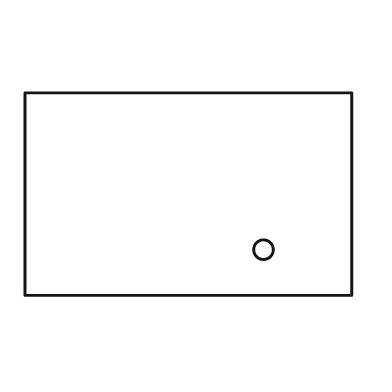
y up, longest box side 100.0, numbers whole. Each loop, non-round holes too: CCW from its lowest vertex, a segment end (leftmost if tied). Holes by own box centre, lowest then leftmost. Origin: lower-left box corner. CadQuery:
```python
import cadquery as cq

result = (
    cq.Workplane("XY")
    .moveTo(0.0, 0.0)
    .lineTo(100.0, 0.0)
    .lineTo(100.0, 62.0)
    .lineTo(0.0, 62.0)
    .close()
    .moveTo(73.0, 14.0)
    .circle(3.0)
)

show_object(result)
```